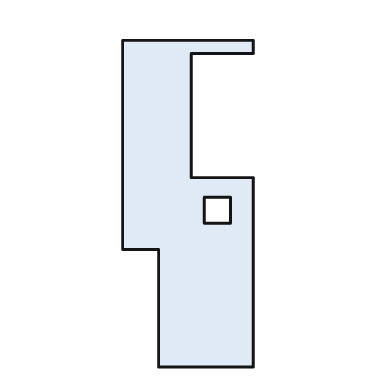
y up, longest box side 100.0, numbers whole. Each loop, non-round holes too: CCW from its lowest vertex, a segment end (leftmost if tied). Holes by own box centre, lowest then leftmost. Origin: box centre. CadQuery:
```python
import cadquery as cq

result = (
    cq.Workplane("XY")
    .moveTo(-9.0, -50.0)
    .lineTo(20.0, -50.0)
    .lineTo(20.0, 8.0)
    .lineTo(1.0, 8.0)
    .lineTo(1.0, 46.0)
    .lineTo(20.0, 46.0)
    .lineTo(20.0, 50.0)
    .lineTo(-20.0, 50.0)
    .lineTo(-20.0, -14.0)
    .lineTo(-9.0, -14.0)
    .close()
    .moveTo(5.0, -6.0)
    .lineTo(13.0, -6.0)
    .lineTo(13.0, 2.0)
    .lineTo(5.0, 2.0)
    .close()
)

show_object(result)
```